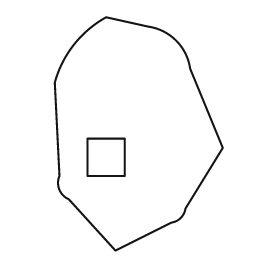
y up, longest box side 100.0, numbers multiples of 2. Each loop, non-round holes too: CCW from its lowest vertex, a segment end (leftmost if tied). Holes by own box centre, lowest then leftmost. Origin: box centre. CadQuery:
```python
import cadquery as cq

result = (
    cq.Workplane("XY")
    .moveTo(-10.0, -50.0)
    .lineTo(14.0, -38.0)
    .threePointArc((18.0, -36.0), (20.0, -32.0))
    .lineTo(36.0, -6.0)
    .lineTo(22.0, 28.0)
    .threePointArc((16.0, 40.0), (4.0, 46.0))
    .lineTo(-14.0, 50.0)
    .threePointArc((-28.0, 38.0), (-36.0, 22.0))
    .lineTo(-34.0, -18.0)
    .threePointArc((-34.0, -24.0), (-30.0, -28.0))
    .close()
    .moveTo(-22.0, -18.0)
    .lineTo(-6.0, -18.0)
    .lineTo(-6.0, -2.0)
    .lineTo(-22.0, -2.0)
    .close()
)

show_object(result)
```